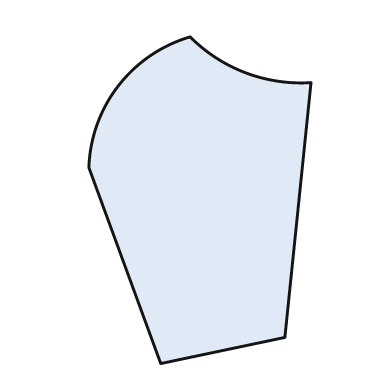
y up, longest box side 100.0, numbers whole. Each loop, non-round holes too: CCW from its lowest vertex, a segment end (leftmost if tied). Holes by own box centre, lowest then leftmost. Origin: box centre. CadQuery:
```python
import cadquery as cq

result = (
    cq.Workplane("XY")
    .moveTo(-12.0, -50.0)
    .lineTo(26.0, -42.0)
    .lineTo(34.0, 36.0)
    .threePointArc((14.0, 39.0), (-3.0, 50.0))
    .threePointArc((-25.0, 35.0), (-34.0, 10.0))
    .close()
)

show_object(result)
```